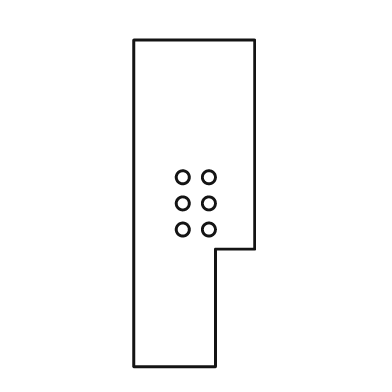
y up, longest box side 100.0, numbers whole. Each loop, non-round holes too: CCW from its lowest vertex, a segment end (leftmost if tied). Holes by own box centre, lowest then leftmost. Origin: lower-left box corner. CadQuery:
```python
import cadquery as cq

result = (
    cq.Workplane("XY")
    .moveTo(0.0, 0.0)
    .lineTo(25.0, 0.0)
    .lineTo(25.0, 36.0)
    .lineTo(37.0, 36.0)
    .lineTo(37.0, 100.0)
    .lineTo(0.0, 100.0)
    .close()
    .moveTo(15.0, 42.0)
    .circle(2.0)
    .moveTo(23.0, 42.0)
    .circle(2.0)
    .moveTo(15.0, 50.0)
    .circle(2.0)
    .moveTo(23.0, 50.0)
    .circle(2.0)
    .moveTo(15.0, 58.0)
    .circle(2.0)
    .moveTo(23.0, 58.0)
    .circle(2.0)
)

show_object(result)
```